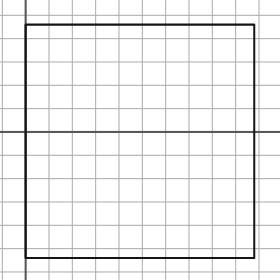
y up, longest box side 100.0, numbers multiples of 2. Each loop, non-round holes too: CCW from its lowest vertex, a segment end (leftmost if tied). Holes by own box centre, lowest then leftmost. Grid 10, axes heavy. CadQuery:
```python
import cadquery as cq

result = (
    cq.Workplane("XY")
    .moveTo(0.0, -54.0)
    .lineTo(98.0, -54.0)
    .lineTo(98.0, 46.0)
    .lineTo(0.0, 46.0)
    .close()
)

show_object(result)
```